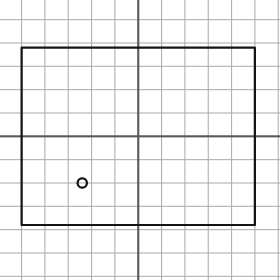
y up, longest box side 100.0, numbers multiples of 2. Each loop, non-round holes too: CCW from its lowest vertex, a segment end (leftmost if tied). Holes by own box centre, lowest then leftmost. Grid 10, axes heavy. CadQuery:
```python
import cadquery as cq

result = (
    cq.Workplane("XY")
    .moveTo(-50.0, -38.0)
    .lineTo(50.0, -38.0)
    .lineTo(50.0, 38.0)
    .lineTo(-50.0, 38.0)
    .close()
    .moveTo(-24.0, -20.0)
    .circle(2.0)
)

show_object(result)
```